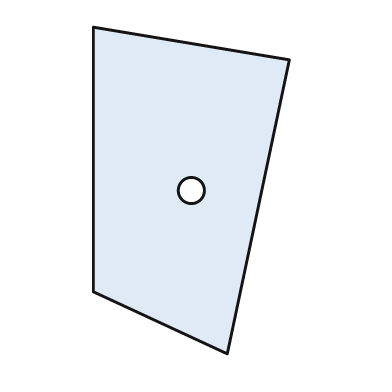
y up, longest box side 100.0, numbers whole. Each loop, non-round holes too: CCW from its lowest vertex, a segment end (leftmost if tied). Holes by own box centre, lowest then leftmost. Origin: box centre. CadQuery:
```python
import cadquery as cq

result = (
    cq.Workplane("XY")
    .moveTo(11.0, -50.0)
    .lineTo(30.0, 40.0)
    .lineTo(-30.0, 50.0)
    .lineTo(-30.0, -31.0)
    .close()
    .moveTo(0.0, 0.0)
    .circle(4.0)
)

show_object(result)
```